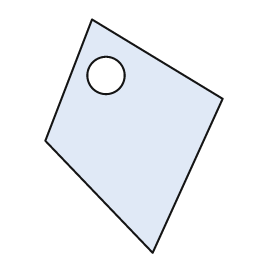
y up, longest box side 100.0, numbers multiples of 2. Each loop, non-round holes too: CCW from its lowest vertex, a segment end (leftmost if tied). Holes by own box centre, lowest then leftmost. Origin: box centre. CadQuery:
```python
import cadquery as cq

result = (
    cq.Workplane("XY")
    .moveTo(8.0, -50.0)
    .lineTo(38.0, 16.0)
    .lineTo(-18.0, 50.0)
    .lineTo(-38.0, -2.0)
    .close()
    .moveTo(-12.0, 26.0)
    .circle(8.0)
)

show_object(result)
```